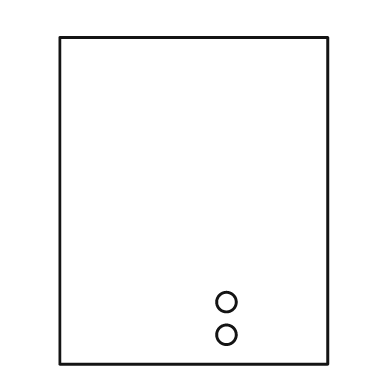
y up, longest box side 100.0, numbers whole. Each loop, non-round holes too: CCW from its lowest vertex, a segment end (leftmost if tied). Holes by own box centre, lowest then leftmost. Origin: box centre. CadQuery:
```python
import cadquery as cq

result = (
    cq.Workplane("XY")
    .moveTo(-41.0, -50.0)
    .lineTo(41.0, -50.0)
    .lineTo(41.0, 50.0)
    .lineTo(-41.0, 50.0)
    .close()
    .moveTo(10.0, -41.0)
    .circle(3.0)
    .moveTo(10.0, -31.0)
    .circle(3.0)
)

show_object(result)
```